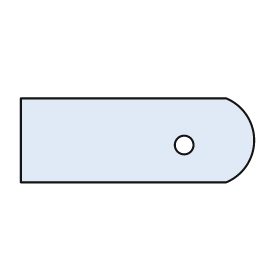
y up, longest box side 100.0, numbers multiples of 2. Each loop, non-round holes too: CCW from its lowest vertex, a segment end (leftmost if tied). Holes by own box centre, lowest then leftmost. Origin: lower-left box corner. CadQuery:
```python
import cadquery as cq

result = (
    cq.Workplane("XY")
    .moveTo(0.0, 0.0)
    .lineTo(88.0, 0.0)
    .threePointArc((100.0, 18.0), (88.0, 36.0))
    .lineTo(0.0, 36.0)
    .close()
    .moveTo(70.0, 16.0)
    .circle(4.0)
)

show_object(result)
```